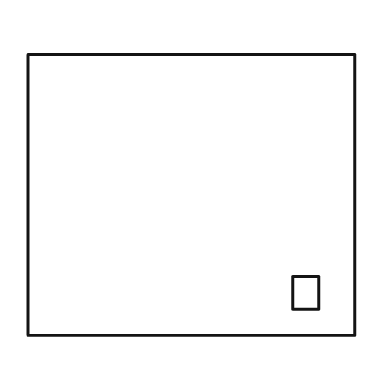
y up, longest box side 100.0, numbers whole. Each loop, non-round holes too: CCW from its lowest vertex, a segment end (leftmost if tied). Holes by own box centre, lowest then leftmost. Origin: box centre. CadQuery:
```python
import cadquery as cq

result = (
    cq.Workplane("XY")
    .moveTo(-50.0, -43.0)
    .lineTo(50.0, -43.0)
    .lineTo(50.0, 43.0)
    .lineTo(-50.0, 43.0)
    .close()
    .moveTo(31.0, -35.0)
    .lineTo(39.0, -35.0)
    .lineTo(39.0, -25.0)
    .lineTo(31.0, -25.0)
    .close()
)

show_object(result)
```